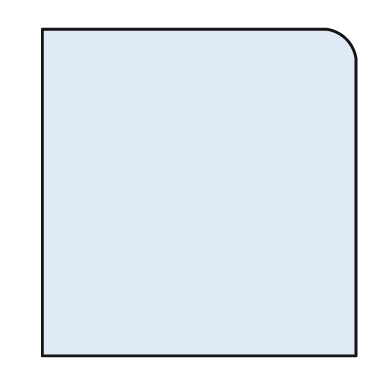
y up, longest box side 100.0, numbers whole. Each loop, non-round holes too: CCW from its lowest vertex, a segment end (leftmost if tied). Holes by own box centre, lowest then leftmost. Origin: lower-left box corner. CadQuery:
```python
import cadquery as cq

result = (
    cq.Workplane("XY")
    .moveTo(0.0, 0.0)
    .lineTo(96.0, 0.0)
    .lineTo(96.0, 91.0)
    .threePointArc((93.0, 97.0), (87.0, 100.0))
    .lineTo(0.0, 100.0)
    .close()
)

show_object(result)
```